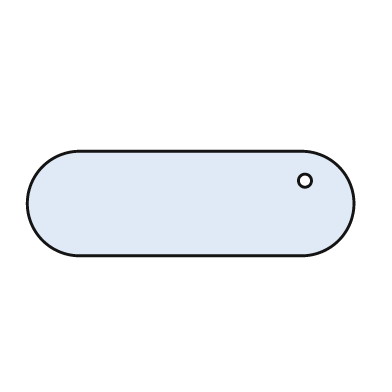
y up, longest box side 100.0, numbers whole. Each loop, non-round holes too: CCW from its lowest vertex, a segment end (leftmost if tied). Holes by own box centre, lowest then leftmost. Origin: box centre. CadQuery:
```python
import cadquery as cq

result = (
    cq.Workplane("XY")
    .moveTo(-34.0, -16.0)
    .lineTo(34.0, -16.0)
    .threePointArc((50.0, 0.0), (34.0, 16.0))
    .lineTo(-34.0, 16.0)
    .threePointArc((-50.0, 0.0), (-34.0, -16.0))
    .close()
    .moveTo(35.0, 7.0)
    .circle(2.0)
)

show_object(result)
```